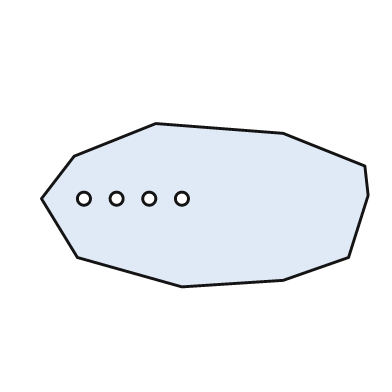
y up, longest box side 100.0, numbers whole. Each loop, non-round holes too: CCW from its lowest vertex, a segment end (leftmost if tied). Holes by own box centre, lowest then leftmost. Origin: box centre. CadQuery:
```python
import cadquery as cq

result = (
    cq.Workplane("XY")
    .moveTo(-7.0, -25.0)
    .lineTo(24.0, -23.0)
    .lineTo(44.0, -16.0)
    .lineTo(50.0, 3.0)
    .lineTo(49.0, 12.0)
    .lineTo(24.0, 22.0)
    .lineTo(-15.0, 25.0)
    .lineTo(-40.0, 15.0)
    .lineTo(-50.0, 2.0)
    .lineTo(-39.0, -16.0)
    .close()
    .moveTo(-37.0, 2.0)
    .circle(2.0)
    .moveTo(-27.0, 2.0)
    .circle(2.0)
    .moveTo(-17.0, 2.0)
    .circle(2.0)
    .moveTo(-7.0, 2.0)
    .circle(2.0)
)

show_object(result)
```